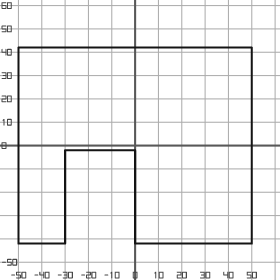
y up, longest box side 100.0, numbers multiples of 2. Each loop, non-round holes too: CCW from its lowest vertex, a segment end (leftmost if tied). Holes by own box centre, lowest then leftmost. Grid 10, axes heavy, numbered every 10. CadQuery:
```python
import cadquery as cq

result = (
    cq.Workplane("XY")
    .moveTo(-50.0, -42.0)
    .lineTo(-30.0, -42.0)
    .lineTo(-30.0, -2.0)
    .lineTo(0.0, -2.0)
    .lineTo(0.0, -42.0)
    .lineTo(50.0, -42.0)
    .lineTo(50.0, 42.0)
    .lineTo(-50.0, 42.0)
    .close()
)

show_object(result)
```